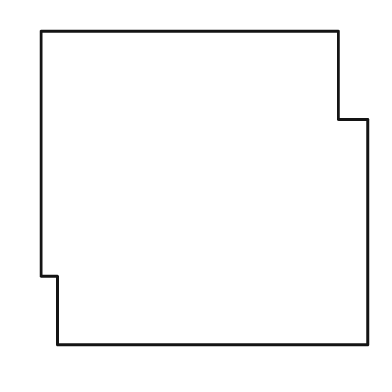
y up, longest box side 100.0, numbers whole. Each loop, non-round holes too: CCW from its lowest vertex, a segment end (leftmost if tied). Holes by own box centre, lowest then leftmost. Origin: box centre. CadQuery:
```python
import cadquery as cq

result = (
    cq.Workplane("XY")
    .moveTo(-45.0, -48.0)
    .lineTo(50.0, -48.0)
    .lineTo(50.0, 21.0)
    .lineTo(41.0, 21.0)
    .lineTo(41.0, 48.0)
    .lineTo(-50.0, 48.0)
    .lineTo(-50.0, -27.0)
    .lineTo(-45.0, -27.0)
    .close()
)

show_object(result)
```